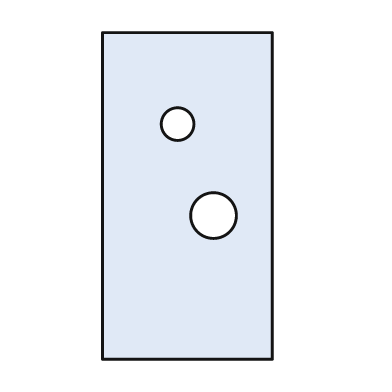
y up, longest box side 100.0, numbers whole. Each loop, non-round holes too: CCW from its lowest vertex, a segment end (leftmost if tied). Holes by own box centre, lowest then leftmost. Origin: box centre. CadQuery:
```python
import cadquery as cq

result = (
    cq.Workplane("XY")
    .moveTo(-26.0, -50.0)
    .lineTo(26.0, -50.0)
    .lineTo(26.0, 50.0)
    .lineTo(-26.0, 50.0)
    .close()
    .moveTo(8.0, -6.0)
    .circle(7.0)
    .moveTo(-3.0, 22.0)
    .circle(5.0)
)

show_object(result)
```